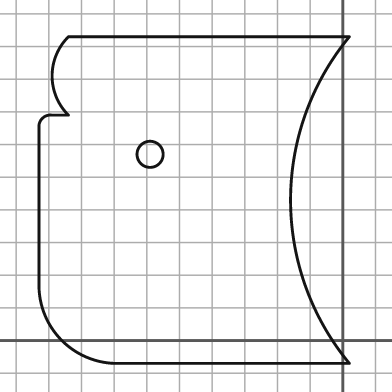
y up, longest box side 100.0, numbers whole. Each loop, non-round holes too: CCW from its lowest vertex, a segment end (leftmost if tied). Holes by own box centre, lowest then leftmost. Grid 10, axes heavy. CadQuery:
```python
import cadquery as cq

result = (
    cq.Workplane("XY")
    .moveTo(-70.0, -7.0)
    .lineTo(2.0, -7.0)
    .threePointArc((-16.0, 43.0), (2.0, 93.0))
    .lineTo(-84.0, 93.0)
    .threePointArc((-89.0, 81.0), (-84.0, 69.0))
    .lineTo(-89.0, 69.0)
    .threePointArc((-92.0, 68.0), (-93.0, 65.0))
    .lineTo(-93.0, 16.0)
    .threePointArc((-86.0, 0.0), (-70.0, -7.0))
    .close()
    .moveTo(-59.0, 57.0)
    .circle(4.0)
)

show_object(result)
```